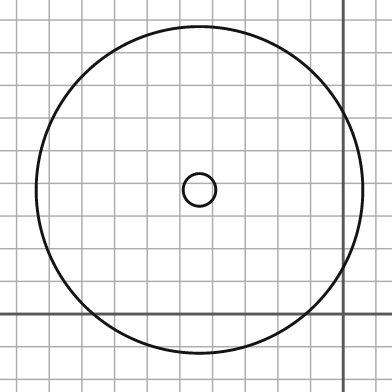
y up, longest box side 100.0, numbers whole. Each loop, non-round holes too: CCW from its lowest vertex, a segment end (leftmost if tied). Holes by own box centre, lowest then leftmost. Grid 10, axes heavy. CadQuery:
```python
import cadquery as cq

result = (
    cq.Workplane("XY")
    .moveTo(-44.0, 38.0)
    .circle(50.0)
    .moveTo(-44.0, 38.0)
    .circle(5.0)
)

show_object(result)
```